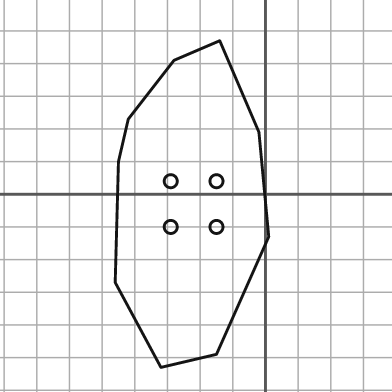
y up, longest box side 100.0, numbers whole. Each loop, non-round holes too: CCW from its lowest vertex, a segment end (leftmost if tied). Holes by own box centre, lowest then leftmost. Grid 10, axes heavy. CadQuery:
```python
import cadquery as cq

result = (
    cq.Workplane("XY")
    .moveTo(-32.0, -53.0)
    .lineTo(-15.0, -49.0)
    .lineTo(1.0, -13.0)
    .lineTo(-2.0, 19.0)
    .lineTo(-14.0, 47.0)
    .lineTo(-28.0, 41.0)
    .lineTo(-42.0, 23.0)
    .lineTo(-45.0, 10.0)
    .lineTo(-46.0, -27.0)
    .close()
    .moveTo(-29.0, -10.0)
    .circle(2.0)
    .moveTo(-15.0, -10.0)
    .circle(2.0)
    .moveTo(-29.0, 4.0)
    .circle(2.0)
    .moveTo(-15.0, 4.0)
    .circle(2.0)
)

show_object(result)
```